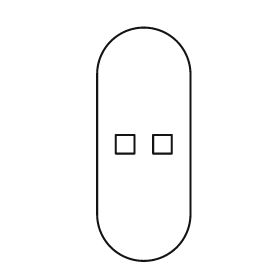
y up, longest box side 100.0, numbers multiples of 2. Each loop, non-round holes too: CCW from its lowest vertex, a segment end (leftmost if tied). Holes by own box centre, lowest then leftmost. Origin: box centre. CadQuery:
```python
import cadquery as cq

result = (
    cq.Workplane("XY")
    .moveTo(-20.0, -30.0)
    .threePointArc((0.0, -50.0), (20.0, -30.0))
    .lineTo(20.0, 30.0)
    .threePointArc((0.0, 50.0), (-20.0, 30.0))
    .close()
    .moveTo(-12.0, -4.0)
    .lineTo(-4.0, -4.0)
    .lineTo(-4.0, 4.0)
    .lineTo(-12.0, 4.0)
    .close()
    .moveTo(4.0, -4.0)
    .lineTo(12.0, -4.0)
    .lineTo(12.0, 4.0)
    .lineTo(4.0, 4.0)
    .close()
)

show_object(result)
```